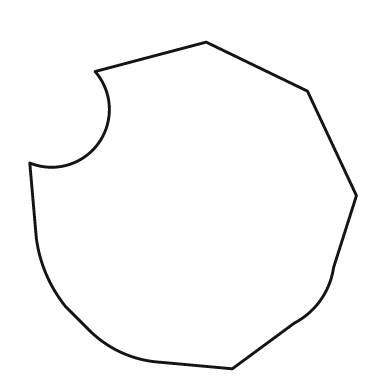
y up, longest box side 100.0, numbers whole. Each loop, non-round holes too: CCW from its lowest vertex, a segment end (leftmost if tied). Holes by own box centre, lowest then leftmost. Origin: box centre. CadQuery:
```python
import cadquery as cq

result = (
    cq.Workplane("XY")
    .moveTo(12.0, -50.0)
    .lineTo(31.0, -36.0)
    .threePointArc((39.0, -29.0), (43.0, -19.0))
    .lineTo(50.0, 3.0)
    .lineTo(35.0, 35.0)
    .lineTo(4.0, 50.0)
    .lineTo(-30.0, 41.0)
    .threePointArc((-29.0, 19.0), (-50.0, 13.0))
    .lineTo(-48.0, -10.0)
    .threePointArc((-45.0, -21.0), (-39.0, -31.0))
    .lineTo(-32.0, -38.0)
    .threePointArc((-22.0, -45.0), (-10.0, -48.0))
    .close()
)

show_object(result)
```